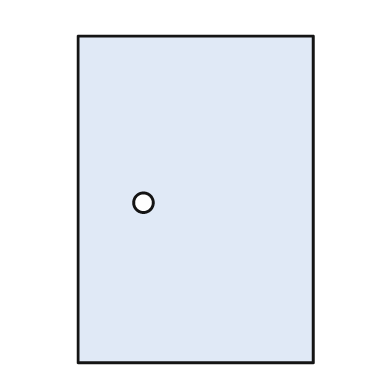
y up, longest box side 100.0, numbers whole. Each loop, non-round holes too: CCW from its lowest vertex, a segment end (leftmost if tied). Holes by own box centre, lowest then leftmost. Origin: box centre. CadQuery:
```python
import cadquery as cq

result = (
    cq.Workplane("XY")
    .moveTo(-36.0, -50.0)
    .lineTo(36.0, -50.0)
    .lineTo(36.0, 50.0)
    .lineTo(-36.0, 50.0)
    .close()
    .moveTo(-16.0, -1.0)
    .circle(3.0)
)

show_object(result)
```